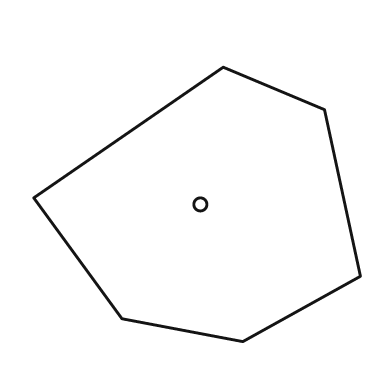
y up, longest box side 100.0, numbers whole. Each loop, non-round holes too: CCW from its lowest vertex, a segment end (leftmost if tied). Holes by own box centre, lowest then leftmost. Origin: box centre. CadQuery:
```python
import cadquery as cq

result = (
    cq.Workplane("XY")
    .moveTo(14.0, -42.0)
    .lineTo(50.0, -22.0)
    .lineTo(39.0, 29.0)
    .lineTo(8.0, 42.0)
    .lineTo(-50.0, 2.0)
    .lineTo(-23.0, -35.0)
    .close()
    .moveTo(1.0, 0.0)
    .circle(2.0)
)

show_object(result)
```